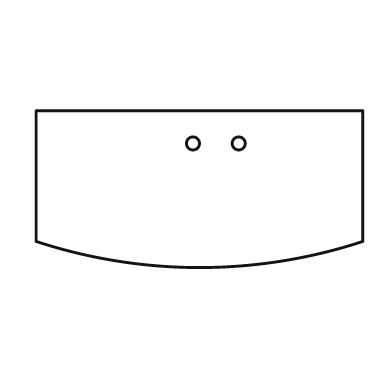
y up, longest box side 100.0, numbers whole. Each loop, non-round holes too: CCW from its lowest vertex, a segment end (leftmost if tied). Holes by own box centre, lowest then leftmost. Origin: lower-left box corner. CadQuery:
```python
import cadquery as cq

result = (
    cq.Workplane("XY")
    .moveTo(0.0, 8.0)
    .threePointArc((50.0, 0.0), (100.0, 8.0))
    .lineTo(100.0, 48.0)
    .lineTo(0.0, 48.0)
    .close()
    .moveTo(48.0, 38.0)
    .circle(2.0)
    .moveTo(62.0, 38.0)
    .circle(2.0)
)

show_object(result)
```